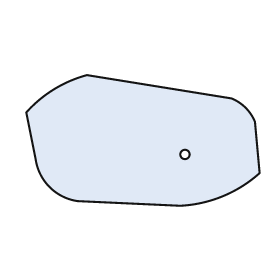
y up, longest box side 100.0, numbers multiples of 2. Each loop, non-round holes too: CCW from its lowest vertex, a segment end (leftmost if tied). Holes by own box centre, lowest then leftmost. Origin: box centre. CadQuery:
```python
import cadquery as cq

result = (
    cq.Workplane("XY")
    .moveTo(16.0, -28.0)
    .threePointArc((34.0, -24.0), (50.0, -14.0))
    .lineTo(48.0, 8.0)
    .threePointArc((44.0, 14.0), (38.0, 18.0))
    .lineTo(-24.0, 28.0)
    .threePointArc((-38.0, 22.0), (-50.0, 12.0))
    .lineTo(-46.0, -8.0)
    .threePointArc((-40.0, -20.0), (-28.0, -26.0))
    .close()
    .moveTo(18.0, -6.0)
    .circle(2.0)
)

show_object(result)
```